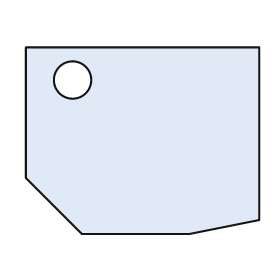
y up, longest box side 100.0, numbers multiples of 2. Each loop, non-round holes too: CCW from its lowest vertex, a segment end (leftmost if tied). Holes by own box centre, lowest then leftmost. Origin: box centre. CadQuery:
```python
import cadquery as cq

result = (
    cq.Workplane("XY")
    .moveTo(-26.0, -40.0)
    .lineTo(20.0, -40.0)
    .lineTo(50.0, -34.0)
    .lineTo(50.0, 40.0)
    .lineTo(-50.0, 40.0)
    .lineTo(-50.0, -16.0)
    .close()
    .moveTo(-30.0, 26.0)
    .circle(8.0)
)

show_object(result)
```